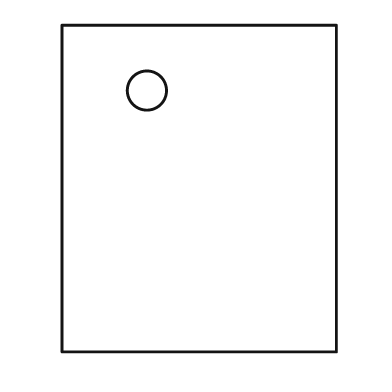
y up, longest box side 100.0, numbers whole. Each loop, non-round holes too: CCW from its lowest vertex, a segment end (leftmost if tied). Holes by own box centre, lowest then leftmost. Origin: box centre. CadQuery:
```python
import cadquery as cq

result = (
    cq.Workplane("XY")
    .moveTo(-42.0, -50.0)
    .lineTo(42.0, -50.0)
    .lineTo(42.0, 50.0)
    .lineTo(-42.0, 50.0)
    .close()
    .moveTo(-16.0, 30.0)
    .circle(6.0)
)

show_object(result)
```